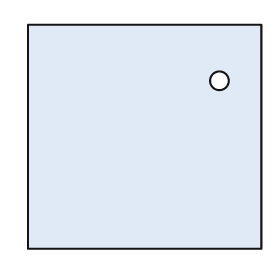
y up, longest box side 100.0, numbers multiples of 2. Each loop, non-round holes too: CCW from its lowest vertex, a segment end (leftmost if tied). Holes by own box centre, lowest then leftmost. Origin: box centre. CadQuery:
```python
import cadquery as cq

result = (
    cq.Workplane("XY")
    .moveTo(-50.0, -48.0)
    .lineTo(50.0, -48.0)
    .lineTo(50.0, 48.0)
    .lineTo(-50.0, 48.0)
    .close()
    .moveTo(32.0, 24.0)
    .circle(4.0)
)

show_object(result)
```